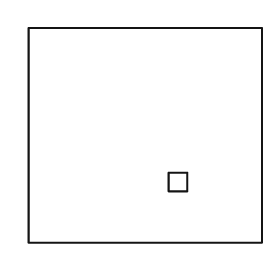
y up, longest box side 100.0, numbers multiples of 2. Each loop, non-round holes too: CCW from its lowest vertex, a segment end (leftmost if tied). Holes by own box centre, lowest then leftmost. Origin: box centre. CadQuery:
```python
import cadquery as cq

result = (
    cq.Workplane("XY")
    .moveTo(-50.0, -46.0)
    .lineTo(50.0, -46.0)
    .lineTo(50.0, 46.0)
    .lineTo(-50.0, 46.0)
    .close()
    .moveTo(10.0, -24.0)
    .lineTo(18.0, -24.0)
    .lineTo(18.0, -16.0)
    .lineTo(10.0, -16.0)
    .close()
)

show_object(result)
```